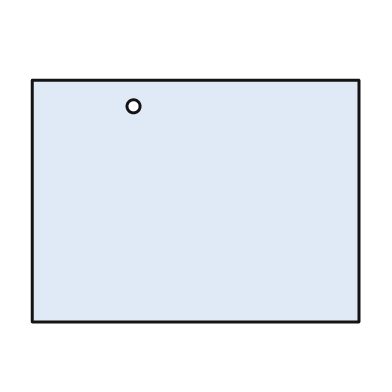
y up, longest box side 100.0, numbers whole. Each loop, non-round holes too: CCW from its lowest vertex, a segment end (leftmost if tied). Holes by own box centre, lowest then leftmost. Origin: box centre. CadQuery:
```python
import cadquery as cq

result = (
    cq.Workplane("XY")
    .moveTo(-50.0, -37.0)
    .lineTo(50.0, -37.0)
    .lineTo(50.0, 37.0)
    .lineTo(-50.0, 37.0)
    .close()
    .moveTo(-19.0, 29.0)
    .circle(2.0)
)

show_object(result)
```